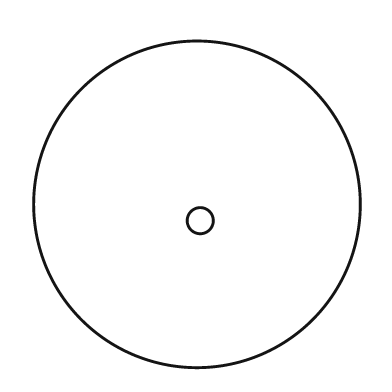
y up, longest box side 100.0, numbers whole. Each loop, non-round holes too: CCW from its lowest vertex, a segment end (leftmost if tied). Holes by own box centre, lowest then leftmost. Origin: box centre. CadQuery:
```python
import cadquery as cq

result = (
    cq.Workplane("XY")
    .moveTo(0.0, 0.0)
    .circle(50.0)
    .moveTo(1.0, -5.0)
    .circle(4.0)
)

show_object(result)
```